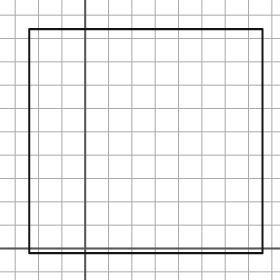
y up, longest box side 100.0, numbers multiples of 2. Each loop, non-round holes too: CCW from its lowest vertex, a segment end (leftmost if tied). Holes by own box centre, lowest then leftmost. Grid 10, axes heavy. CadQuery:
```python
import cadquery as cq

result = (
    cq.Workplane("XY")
    .moveTo(-24.0, -2.0)
    .lineTo(76.0, -2.0)
    .lineTo(76.0, 94.0)
    .lineTo(-24.0, 94.0)
    .close()
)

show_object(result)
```